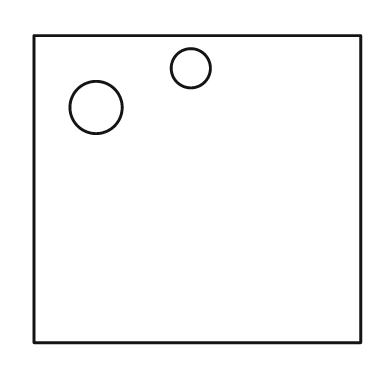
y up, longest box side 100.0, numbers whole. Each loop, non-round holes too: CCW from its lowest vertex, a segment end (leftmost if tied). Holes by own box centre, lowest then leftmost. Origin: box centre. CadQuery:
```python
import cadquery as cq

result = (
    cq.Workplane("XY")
    .moveTo(-50.0, -47.0)
    .lineTo(50.0, -47.0)
    .lineTo(50.0, 47.0)
    .lineTo(-50.0, 47.0)
    .close()
    .moveTo(-31.0, 25.0)
    .circle(8.0)
    .moveTo(-2.0, 37.0)
    .circle(6.0)
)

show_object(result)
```